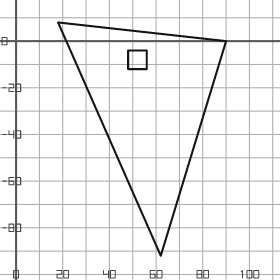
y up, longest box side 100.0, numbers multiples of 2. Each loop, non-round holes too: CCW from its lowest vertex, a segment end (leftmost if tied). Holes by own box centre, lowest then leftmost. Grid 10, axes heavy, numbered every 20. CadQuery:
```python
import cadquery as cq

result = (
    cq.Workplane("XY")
    .moveTo(62.0, -92.0)
    .lineTo(90.0, 0.0)
    .lineTo(18.0, 8.0)
    .close()
    .moveTo(48.0, -12.0)
    .lineTo(56.0, -12.0)
    .lineTo(56.0, -4.0)
    .lineTo(48.0, -4.0)
    .close()
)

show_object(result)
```